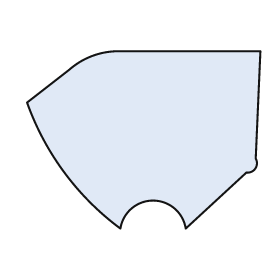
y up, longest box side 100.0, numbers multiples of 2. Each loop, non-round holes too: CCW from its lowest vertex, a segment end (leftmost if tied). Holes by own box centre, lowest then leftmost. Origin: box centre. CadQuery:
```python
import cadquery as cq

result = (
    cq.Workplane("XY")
    .moveTo(-10.0, -38.0)
    .threePointArc((4.0, -26.0), (18.0, -38.0))
    .lineTo(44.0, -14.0)
    .threePointArc((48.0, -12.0), (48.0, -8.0))
    .lineTo(50.0, 38.0)
    .lineTo(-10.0, 38.0)
    .threePointArc((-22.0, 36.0), (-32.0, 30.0))
    .lineTo(-50.0, 16.0)
    .threePointArc((-34.0, -14.0), (-10.0, -38.0))
    .close()
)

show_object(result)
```